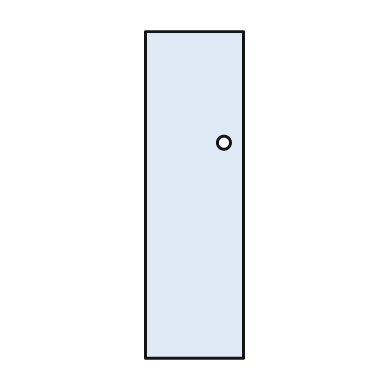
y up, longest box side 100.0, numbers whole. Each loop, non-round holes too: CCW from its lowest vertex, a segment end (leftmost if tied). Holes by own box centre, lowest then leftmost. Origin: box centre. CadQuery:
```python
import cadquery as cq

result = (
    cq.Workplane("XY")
    .moveTo(-15.0, -50.0)
    .lineTo(15.0, -50.0)
    .lineTo(15.0, 50.0)
    .lineTo(-15.0, 50.0)
    .close()
    .moveTo(9.0, 16.0)
    .circle(2.0)
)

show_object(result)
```